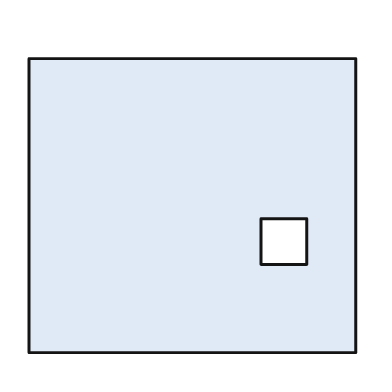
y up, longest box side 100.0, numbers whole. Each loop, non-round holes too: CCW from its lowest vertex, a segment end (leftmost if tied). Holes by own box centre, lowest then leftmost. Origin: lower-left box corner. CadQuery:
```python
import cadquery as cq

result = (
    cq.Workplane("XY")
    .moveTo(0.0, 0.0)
    .lineTo(100.0, 0.0)
    .lineTo(100.0, 90.0)
    .lineTo(0.0, 90.0)
    .close()
    .moveTo(71.0, 27.0)
    .lineTo(85.0, 27.0)
    .lineTo(85.0, 41.0)
    .lineTo(71.0, 41.0)
    .close()
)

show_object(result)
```